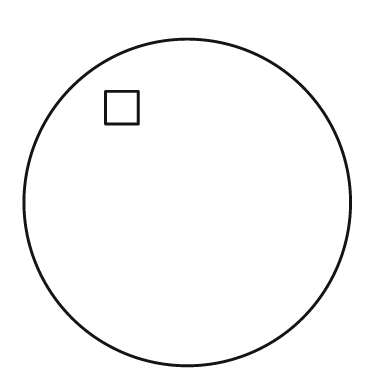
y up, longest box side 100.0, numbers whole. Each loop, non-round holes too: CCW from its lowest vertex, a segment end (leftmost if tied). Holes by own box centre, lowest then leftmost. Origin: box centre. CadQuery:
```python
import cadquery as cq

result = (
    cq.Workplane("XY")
    .moveTo(0.0, 0.0)
    .circle(50.0)
    .moveTo(-25.0, 24.0)
    .lineTo(-15.0, 24.0)
    .lineTo(-15.0, 34.0)
    .lineTo(-25.0, 34.0)
    .close()
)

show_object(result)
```